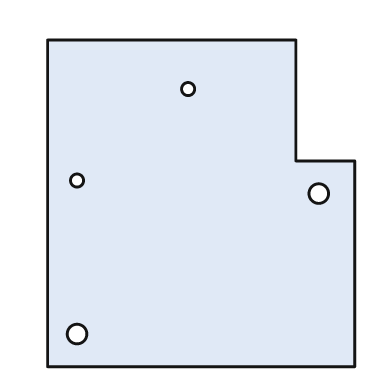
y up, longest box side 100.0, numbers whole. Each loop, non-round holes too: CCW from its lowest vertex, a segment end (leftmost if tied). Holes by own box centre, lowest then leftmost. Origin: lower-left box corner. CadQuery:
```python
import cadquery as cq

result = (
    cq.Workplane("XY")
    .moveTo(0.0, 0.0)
    .lineTo(94.0, 0.0)
    .lineTo(94.0, 63.0)
    .lineTo(76.0, 63.0)
    .lineTo(76.0, 100.0)
    .lineTo(0.0, 100.0)
    .close()
    .moveTo(9.0, 10.0)
    .circle(3.0)
    .moveTo(83.0, 53.0)
    .circle(3.0)
    .moveTo(9.0, 57.0)
    .circle(2.0)
    .moveTo(43.0, 85.0)
    .circle(2.0)
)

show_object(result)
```